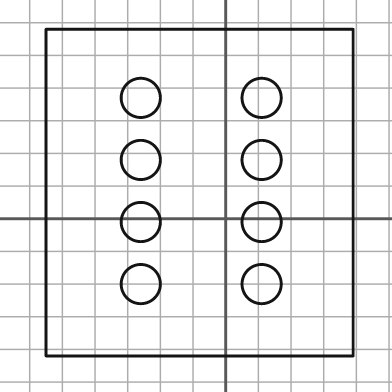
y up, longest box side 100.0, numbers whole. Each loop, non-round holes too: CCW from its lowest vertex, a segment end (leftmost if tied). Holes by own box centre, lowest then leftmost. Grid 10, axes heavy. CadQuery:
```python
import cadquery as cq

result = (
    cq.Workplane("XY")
    .moveTo(-55.0, -42.0)
    .lineTo(39.0, -42.0)
    .lineTo(39.0, 58.0)
    .lineTo(-55.0, 58.0)
    .close()
    .moveTo(-26.0, -20.0)
    .circle(6.0)
    .moveTo(11.0, -20.0)
    .circle(6.0)
    .moveTo(-26.0, -1.0)
    .circle(6.0)
    .moveTo(11.0, -1.0)
    .circle(6.0)
    .moveTo(-26.0, 18.0)
    .circle(6.0)
    .moveTo(11.0, 18.0)
    .circle(6.0)
    .moveTo(-26.0, 37.0)
    .circle(6.0)
    .moveTo(11.0, 37.0)
    .circle(6.0)
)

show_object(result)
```